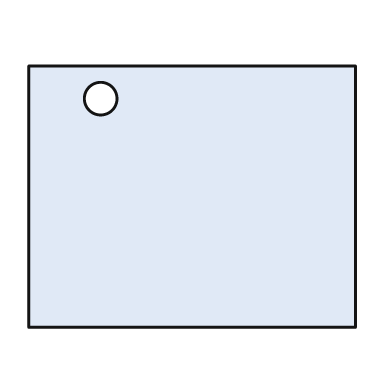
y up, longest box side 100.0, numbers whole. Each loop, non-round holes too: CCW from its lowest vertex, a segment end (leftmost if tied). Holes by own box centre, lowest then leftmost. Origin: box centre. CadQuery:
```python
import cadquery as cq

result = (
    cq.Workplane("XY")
    .moveTo(-50.0, -40.0)
    .lineTo(50.0, -40.0)
    .lineTo(50.0, 40.0)
    .lineTo(-50.0, 40.0)
    .close()
    .moveTo(-28.0, 30.0)
    .circle(5.0)
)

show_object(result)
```